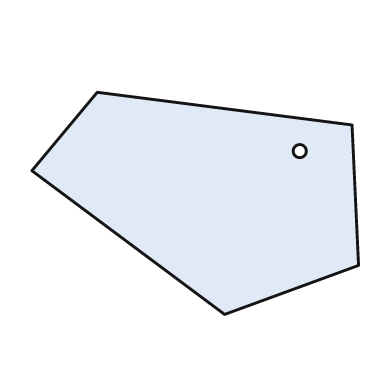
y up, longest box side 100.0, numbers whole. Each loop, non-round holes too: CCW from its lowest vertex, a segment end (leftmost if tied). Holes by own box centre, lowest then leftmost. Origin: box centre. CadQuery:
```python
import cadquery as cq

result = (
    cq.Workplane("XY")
    .moveTo(9.0, -34.0)
    .lineTo(50.0, -19.0)
    .lineTo(48.0, 24.0)
    .lineTo(-30.0, 34.0)
    .lineTo(-50.0, 10.0)
    .close()
    .moveTo(32.0, 16.0)
    .circle(2.0)
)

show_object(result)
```